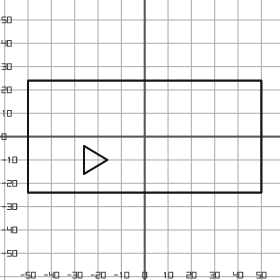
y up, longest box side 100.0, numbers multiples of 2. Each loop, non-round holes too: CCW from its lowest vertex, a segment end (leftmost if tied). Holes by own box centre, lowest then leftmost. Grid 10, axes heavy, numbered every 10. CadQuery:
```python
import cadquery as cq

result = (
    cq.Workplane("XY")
    .moveTo(-50.0, -24.0)
    .lineTo(50.0, -24.0)
    .lineTo(50.0, 24.0)
    .lineTo(-50.0, 24.0)
    .close()
    .moveTo(-26.0, -16.0)
    .lineTo(-16.0, -10.0)
    .lineTo(-26.0, -4.0)
    .close()
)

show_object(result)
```